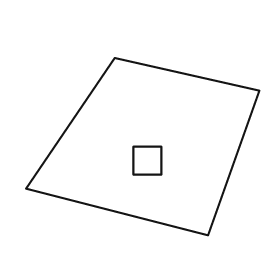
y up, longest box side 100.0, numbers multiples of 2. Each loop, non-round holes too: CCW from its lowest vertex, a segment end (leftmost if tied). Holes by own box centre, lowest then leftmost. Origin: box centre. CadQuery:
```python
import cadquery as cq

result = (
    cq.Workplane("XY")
    .moveTo(28.0, -38.0)
    .lineTo(50.0, 24.0)
    .lineTo(-12.0, 38.0)
    .lineTo(-50.0, -18.0)
    .close()
    .moveTo(-4.0, -12.0)
    .lineTo(8.0, -12.0)
    .lineTo(8.0, 0.0)
    .lineTo(-4.0, 0.0)
    .close()
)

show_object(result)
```